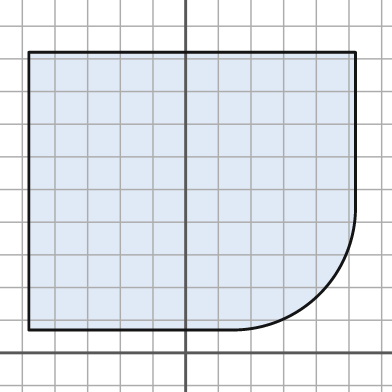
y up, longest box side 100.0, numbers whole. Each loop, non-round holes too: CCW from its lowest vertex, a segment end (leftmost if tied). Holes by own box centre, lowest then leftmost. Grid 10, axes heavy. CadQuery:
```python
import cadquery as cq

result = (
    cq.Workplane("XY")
    .moveTo(-48.0, 7.0)
    .lineTo(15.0, 7.0)
    .threePointArc((41.0, 18.0), (52.0, 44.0))
    .lineTo(52.0, 92.0)
    .lineTo(-48.0, 92.0)
    .close()
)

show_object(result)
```